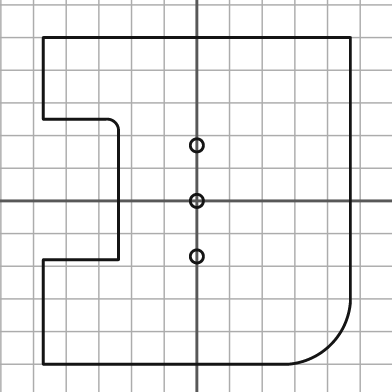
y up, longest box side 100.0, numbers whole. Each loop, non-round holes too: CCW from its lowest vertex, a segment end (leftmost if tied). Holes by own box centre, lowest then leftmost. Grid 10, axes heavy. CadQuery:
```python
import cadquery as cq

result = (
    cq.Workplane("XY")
    .moveTo(-47.0, -50.0)
    .lineTo(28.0, -50.0)
    .threePointArc((41.0, -44.0), (47.0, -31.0))
    .lineTo(47.0, 50.0)
    .lineTo(-47.0, 50.0)
    .lineTo(-47.0, 25.0)
    .lineTo(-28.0, 25.0)
    .threePointArc((-25.0, 24.0), (-24.0, 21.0))
    .lineTo(-24.0, -18.0)
    .lineTo(-47.0, -18.0)
    .close()
    .moveTo(0.0, -17.0)
    .circle(2.0)
    .moveTo(0.0, 0.0)
    .circle(2.0)
    .moveTo(0.0, 17.0)
    .circle(2.0)
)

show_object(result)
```